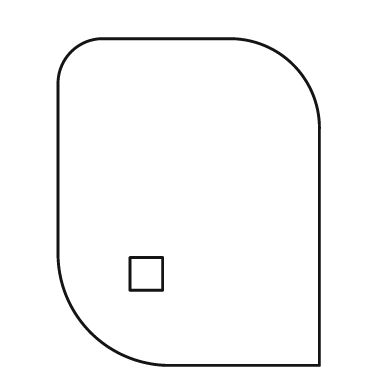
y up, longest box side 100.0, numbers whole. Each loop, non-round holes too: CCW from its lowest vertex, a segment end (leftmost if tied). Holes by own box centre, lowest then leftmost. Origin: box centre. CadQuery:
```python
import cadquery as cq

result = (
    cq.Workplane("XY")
    .moveTo(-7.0, -50.0)
    .lineTo(40.0, -50.0)
    .lineTo(40.0, 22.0)
    .threePointArc((32.0, 42.0), (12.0, 50.0))
    .lineTo(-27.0, 50.0)
    .threePointArc((-36.0, 46.0), (-40.0, 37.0))
    .lineTo(-40.0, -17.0)
    .threePointArc((-30.0, -40.0), (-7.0, -50.0))
    .close()
    .moveTo(-18.0, -27.0)
    .lineTo(-8.0, -27.0)
    .lineTo(-8.0, -17.0)
    .lineTo(-18.0, -17.0)
    .close()
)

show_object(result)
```